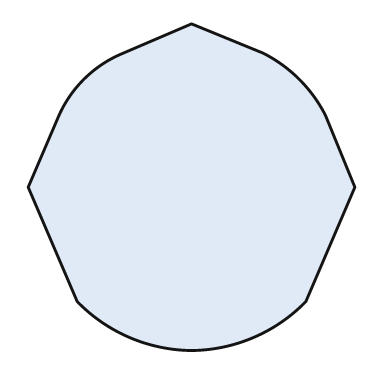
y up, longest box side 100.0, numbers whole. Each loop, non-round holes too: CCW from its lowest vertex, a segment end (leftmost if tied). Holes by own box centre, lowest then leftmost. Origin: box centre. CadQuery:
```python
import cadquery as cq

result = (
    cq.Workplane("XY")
    .moveTo(0.0, -50.0)
    .threePointArc((19.0, -46.0), (35.0, -35.0))
    .lineTo(50.0, 0.0)
    .lineTo(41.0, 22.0)
    .threePointArc((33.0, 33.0), (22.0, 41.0))
    .lineTo(0.0, 50.0)
    .lineTo(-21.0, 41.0)
    .threePointArc((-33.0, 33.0), (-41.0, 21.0))
    .lineTo(-50.0, 0.0)
    .lineTo(-35.0, -35.0)
    .threePointArc((-19.0, -46.0), (0.0, -50.0))
    .close()
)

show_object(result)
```